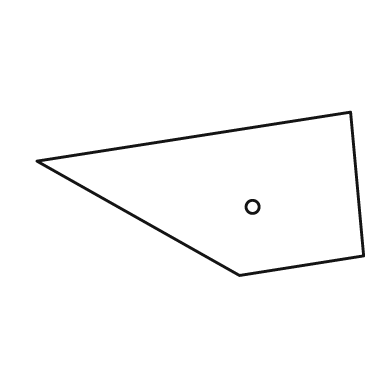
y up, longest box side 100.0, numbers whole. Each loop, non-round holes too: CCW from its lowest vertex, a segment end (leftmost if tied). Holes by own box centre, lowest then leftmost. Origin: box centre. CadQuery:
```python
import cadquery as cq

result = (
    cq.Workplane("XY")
    .moveTo(12.0, -25.0)
    .lineTo(50.0, -19.0)
    .lineTo(46.0, 25.0)
    .lineTo(-50.0, 10.0)
    .close()
    .moveTo(16.0, -4.0)
    .circle(2.0)
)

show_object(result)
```